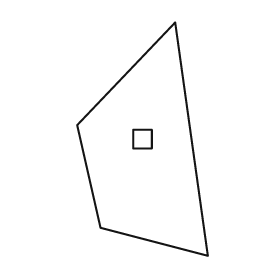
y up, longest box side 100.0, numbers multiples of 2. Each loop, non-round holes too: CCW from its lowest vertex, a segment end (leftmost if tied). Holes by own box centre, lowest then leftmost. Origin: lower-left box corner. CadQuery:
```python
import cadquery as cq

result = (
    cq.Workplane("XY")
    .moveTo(56.0, 0.0)
    .lineTo(42.0, 100.0)
    .lineTo(0.0, 56.0)
    .lineTo(10.0, 12.0)
    .close()
    .moveTo(24.0, 46.0)
    .lineTo(32.0, 46.0)
    .lineTo(32.0, 54.0)
    .lineTo(24.0, 54.0)
    .close()
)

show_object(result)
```